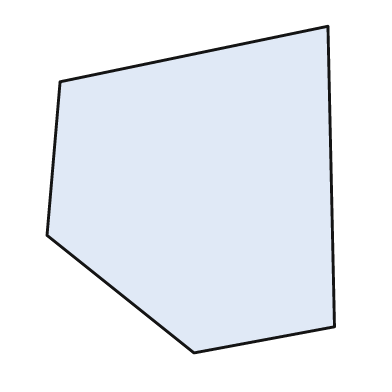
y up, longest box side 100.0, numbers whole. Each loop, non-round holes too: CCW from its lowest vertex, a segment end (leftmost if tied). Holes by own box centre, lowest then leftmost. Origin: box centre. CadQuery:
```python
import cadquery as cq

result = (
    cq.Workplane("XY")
    .moveTo(1.0, -50.0)
    .lineTo(44.0, -42.0)
    .lineTo(42.0, 50.0)
    .lineTo(-40.0, 33.0)
    .lineTo(-44.0, -14.0)
    .close()
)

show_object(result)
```